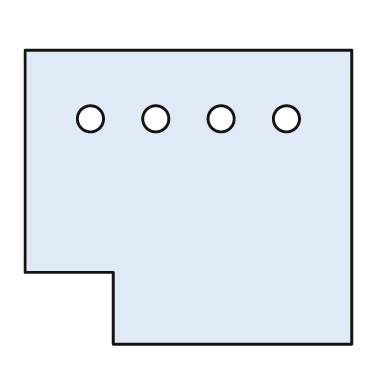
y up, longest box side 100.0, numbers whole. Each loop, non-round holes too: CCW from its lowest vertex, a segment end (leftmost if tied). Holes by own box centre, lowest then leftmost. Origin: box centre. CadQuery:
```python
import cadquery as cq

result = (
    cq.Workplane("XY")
    .moveTo(-23.0, -45.0)
    .lineTo(50.0, -45.0)
    .lineTo(50.0, 45.0)
    .lineTo(-50.0, 45.0)
    .lineTo(-50.0, -23.0)
    .lineTo(-23.0, -23.0)
    .close()
    .moveTo(-30.0, 24.0)
    .circle(4.0)
    .moveTo(-10.0, 24.0)
    .circle(4.0)
    .moveTo(10.0, 24.0)
    .circle(4.0)
    .moveTo(30.0, 24.0)
    .circle(4.0)
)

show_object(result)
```